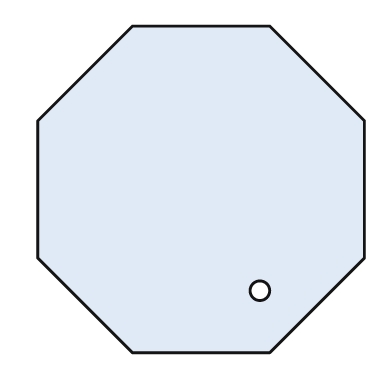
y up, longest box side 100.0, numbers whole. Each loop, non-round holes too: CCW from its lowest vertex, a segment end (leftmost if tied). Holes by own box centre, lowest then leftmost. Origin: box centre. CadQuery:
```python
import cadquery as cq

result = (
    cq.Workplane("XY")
    .moveTo(-21.0, -50.0)
    .lineTo(21.0, -50.0)
    .lineTo(50.0, -21.0)
    .lineTo(50.0, 21.0)
    .lineTo(21.0, 50.0)
    .lineTo(-21.0, 50.0)
    .lineTo(-50.0, 21.0)
    .lineTo(-50.0, -21.0)
    .close()
    .moveTo(18.0, -31.0)
    .circle(3.0)
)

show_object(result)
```